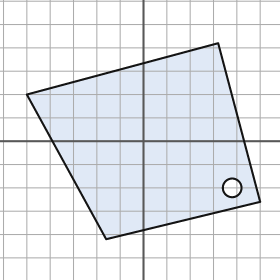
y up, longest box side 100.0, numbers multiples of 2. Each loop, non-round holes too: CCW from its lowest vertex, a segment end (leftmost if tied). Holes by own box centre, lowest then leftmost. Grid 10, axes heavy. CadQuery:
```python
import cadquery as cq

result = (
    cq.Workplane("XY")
    .moveTo(-16.0, -42.0)
    .lineTo(50.0, -26.0)
    .lineTo(32.0, 42.0)
    .lineTo(-50.0, 20.0)
    .close()
    .moveTo(38.0, -20.0)
    .circle(4.0)
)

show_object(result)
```